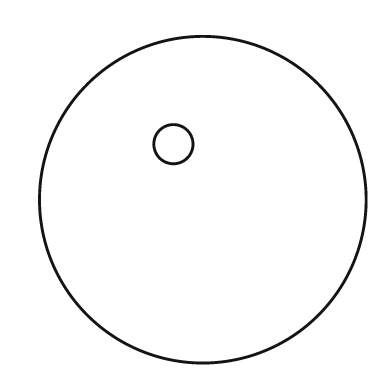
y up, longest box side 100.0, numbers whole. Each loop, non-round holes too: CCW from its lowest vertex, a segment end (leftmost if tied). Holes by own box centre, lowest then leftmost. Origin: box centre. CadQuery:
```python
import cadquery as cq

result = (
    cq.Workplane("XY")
    .moveTo(0.0, 0.0)
    .circle(50.0)
    .moveTo(-9.0, 17.0)
    .circle(6.0)
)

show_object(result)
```